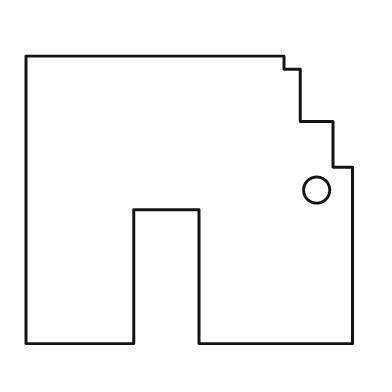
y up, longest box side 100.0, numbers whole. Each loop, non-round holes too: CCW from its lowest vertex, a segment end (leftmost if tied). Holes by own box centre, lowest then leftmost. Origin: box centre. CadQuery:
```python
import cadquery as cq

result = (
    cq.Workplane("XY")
    .moveTo(-50.0, -44.0)
    .lineTo(-17.0, -44.0)
    .lineTo(-17.0, -3.0)
    .lineTo(3.0, -3.0)
    .lineTo(3.0, -44.0)
    .lineTo(50.0, -44.0)
    .lineTo(50.0, 10.0)
    .lineTo(44.0, 10.0)
    .lineTo(44.0, 24.0)
    .lineTo(34.0, 24.0)
    .lineTo(34.0, 40.0)
    .lineTo(29.0, 40.0)
    .lineTo(29.0, 44.0)
    .lineTo(-50.0, 44.0)
    .close()
    .moveTo(39.0, 3.0)
    .circle(4.0)
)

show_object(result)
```